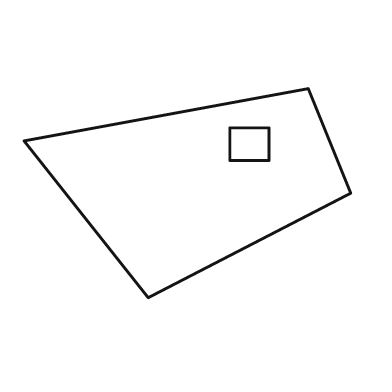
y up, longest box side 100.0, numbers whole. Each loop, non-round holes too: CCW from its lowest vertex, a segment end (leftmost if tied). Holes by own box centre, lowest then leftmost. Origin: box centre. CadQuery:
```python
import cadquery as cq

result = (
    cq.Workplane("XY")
    .moveTo(-12.0, -32.0)
    .lineTo(50.0, 0.0)
    .lineTo(37.0, 32.0)
    .lineTo(-50.0, 16.0)
    .close()
    .moveTo(13.0, 10.0)
    .lineTo(25.0, 10.0)
    .lineTo(25.0, 20.0)
    .lineTo(13.0, 20.0)
    .close()
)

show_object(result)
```